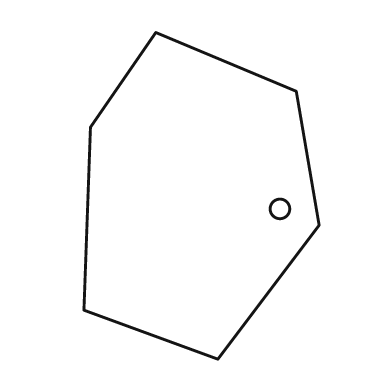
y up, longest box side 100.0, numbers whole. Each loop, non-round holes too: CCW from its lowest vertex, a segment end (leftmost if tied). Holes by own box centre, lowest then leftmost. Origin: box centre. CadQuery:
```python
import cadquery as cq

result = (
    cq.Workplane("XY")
    .moveTo(5.0, -50.0)
    .lineTo(36.0, -9.0)
    .lineTo(29.0, 32.0)
    .lineTo(-14.0, 50.0)
    .lineTo(-34.0, 21.0)
    .lineTo(-36.0, -35.0)
    .close()
    .moveTo(24.0, -4.0)
    .circle(3.0)
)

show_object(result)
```